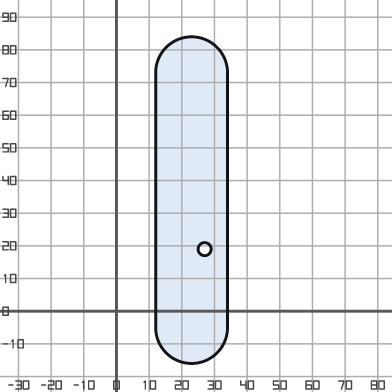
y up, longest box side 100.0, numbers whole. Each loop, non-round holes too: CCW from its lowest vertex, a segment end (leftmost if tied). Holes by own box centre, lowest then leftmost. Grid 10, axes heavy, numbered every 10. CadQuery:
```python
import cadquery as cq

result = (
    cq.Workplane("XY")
    .moveTo(12.0, -5.0)
    .threePointArc((23.0, -16.0), (34.0, -5.0))
    .lineTo(34.0, 73.0)
    .threePointArc((23.0, 84.0), (12.0, 73.0))
    .close()
    .moveTo(27.0, 19.0)
    .circle(2.0)
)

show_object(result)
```